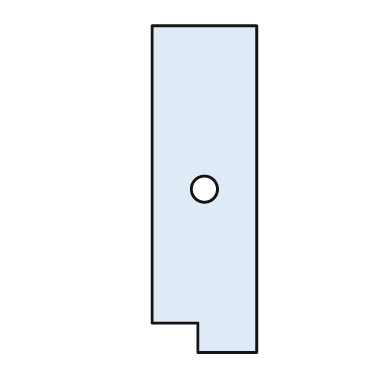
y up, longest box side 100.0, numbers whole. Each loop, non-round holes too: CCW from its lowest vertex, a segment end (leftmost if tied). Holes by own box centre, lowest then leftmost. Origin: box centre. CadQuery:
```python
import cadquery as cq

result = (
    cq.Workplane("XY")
    .moveTo(-2.0, -50.0)
    .lineTo(16.0, -50.0)
    .lineTo(16.0, 50.0)
    .lineTo(-16.0, 50.0)
    .lineTo(-16.0, -41.0)
    .lineTo(-2.0, -41.0)
    .close()
    .moveTo(0.0, 0.0)
    .circle(4.0)
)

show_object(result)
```